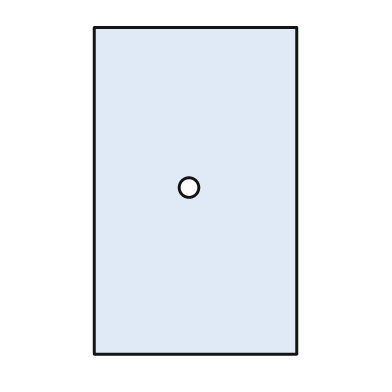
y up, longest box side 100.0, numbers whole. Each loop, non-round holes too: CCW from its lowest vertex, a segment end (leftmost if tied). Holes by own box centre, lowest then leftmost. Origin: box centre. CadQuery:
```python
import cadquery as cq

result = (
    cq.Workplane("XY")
    .moveTo(-31.0, -50.0)
    .lineTo(31.0, -50.0)
    .lineTo(31.0, 50.0)
    .lineTo(-31.0, 50.0)
    .close()
    .moveTo(-2.0, 1.0)
    .circle(3.0)
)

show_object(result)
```